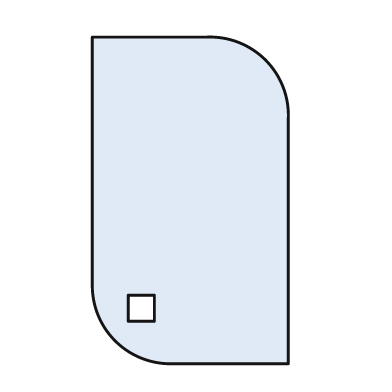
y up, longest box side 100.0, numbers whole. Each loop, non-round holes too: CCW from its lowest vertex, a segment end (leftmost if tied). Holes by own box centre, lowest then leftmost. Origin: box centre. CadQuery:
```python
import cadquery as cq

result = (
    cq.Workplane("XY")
    .moveTo(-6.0, -50.0)
    .lineTo(30.0, -50.0)
    .lineTo(30.0, 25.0)
    .threePointArc((23.0, 43.0), (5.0, 50.0))
    .lineTo(-30.0, 50.0)
    .lineTo(-30.0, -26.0)
    .threePointArc((-23.0, -43.0), (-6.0, -50.0))
    .close()
    .moveTo(-19.0, -37.0)
    .lineTo(-11.0, -37.0)
    .lineTo(-11.0, -29.0)
    .lineTo(-19.0, -29.0)
    .close()
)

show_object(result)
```